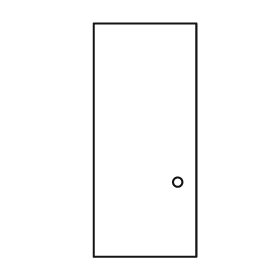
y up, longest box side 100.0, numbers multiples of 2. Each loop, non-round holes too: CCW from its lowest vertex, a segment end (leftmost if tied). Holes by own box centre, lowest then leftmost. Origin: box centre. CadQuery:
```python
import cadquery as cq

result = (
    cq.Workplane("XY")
    .moveTo(-22.0, -50.0)
    .lineTo(22.0, -50.0)
    .lineTo(22.0, 50.0)
    .lineTo(-22.0, 50.0)
    .close()
    .moveTo(14.0, -18.0)
    .circle(2.0)
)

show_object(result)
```